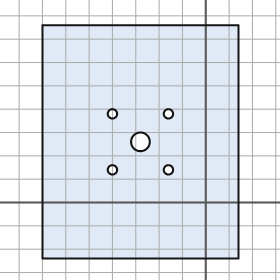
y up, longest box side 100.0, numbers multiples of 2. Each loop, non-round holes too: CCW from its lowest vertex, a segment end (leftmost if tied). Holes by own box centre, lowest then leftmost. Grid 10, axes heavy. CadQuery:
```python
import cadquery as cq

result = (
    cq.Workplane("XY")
    .moveTo(-70.0, -24.0)
    .lineTo(14.0, -24.0)
    .lineTo(14.0, 76.0)
    .lineTo(-70.0, 76.0)
    .close()
    .moveTo(-40.0, 14.0)
    .circle(2.0)
    .moveTo(-16.0, 14.0)
    .circle(2.0)
    .moveTo(-28.0, 26.0)
    .circle(4.0)
    .moveTo(-40.0, 38.0)
    .circle(2.0)
    .moveTo(-16.0, 38.0)
    .circle(2.0)
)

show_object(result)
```